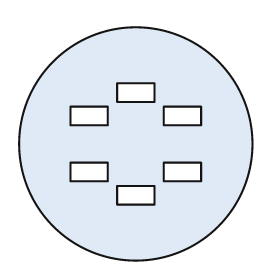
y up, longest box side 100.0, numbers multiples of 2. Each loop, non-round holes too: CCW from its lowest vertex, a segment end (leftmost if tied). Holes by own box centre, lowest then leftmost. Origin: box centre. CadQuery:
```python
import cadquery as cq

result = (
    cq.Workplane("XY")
    .moveTo(0.0, 0.0)
    .circle(50.0)
    .moveTo(-8.0, -26.0)
    .lineTo(8.0, -26.0)
    .lineTo(8.0, -18.0)
    .lineTo(-8.0, -18.0)
    .close()
    .moveTo(-28.0, -16.0)
    .lineTo(-12.0, -16.0)
    .lineTo(-12.0, -8.0)
    .lineTo(-28.0, -8.0)
    .close()
    .moveTo(12.0, -16.0)
    .lineTo(28.0, -16.0)
    .lineTo(28.0, -8.0)
    .lineTo(12.0, -8.0)
    .close()
    .moveTo(-28.0, 8.0)
    .lineTo(-12.0, 8.0)
    .lineTo(-12.0, 16.0)
    .lineTo(-28.0, 16.0)
    .close()
    .moveTo(12.0, 8.0)
    .lineTo(28.0, 8.0)
    .lineTo(28.0, 16.0)
    .lineTo(12.0, 16.0)
    .close()
    .moveTo(-8.0, 18.0)
    .lineTo(8.0, 18.0)
    .lineTo(8.0, 26.0)
    .lineTo(-8.0, 26.0)
    .close()
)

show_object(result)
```